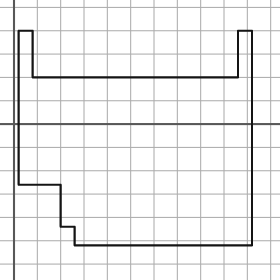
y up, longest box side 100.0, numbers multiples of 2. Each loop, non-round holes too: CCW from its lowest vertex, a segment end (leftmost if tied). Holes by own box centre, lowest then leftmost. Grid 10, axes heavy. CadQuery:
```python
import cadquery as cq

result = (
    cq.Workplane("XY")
    .moveTo(26.0, -52.0)
    .lineTo(102.0, -52.0)
    .lineTo(102.0, 40.0)
    .lineTo(96.0, 40.0)
    .lineTo(96.0, 20.0)
    .lineTo(8.0, 20.0)
    .lineTo(8.0, 40.0)
    .lineTo(2.0, 40.0)
    .lineTo(2.0, -26.0)
    .lineTo(20.0, -26.0)
    .lineTo(20.0, -44.0)
    .lineTo(26.0, -44.0)
    .close()
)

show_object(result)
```